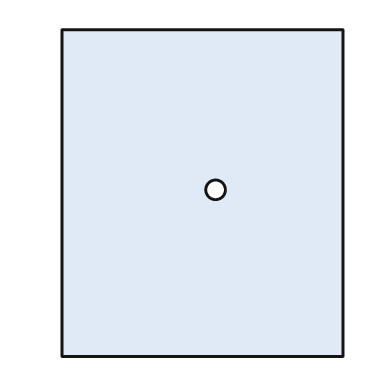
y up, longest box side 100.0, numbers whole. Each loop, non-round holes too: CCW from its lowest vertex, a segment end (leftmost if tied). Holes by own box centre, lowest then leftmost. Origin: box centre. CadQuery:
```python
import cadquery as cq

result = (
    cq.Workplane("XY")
    .moveTo(-43.0, -50.0)
    .lineTo(43.0, -50.0)
    .lineTo(43.0, 50.0)
    .lineTo(-43.0, 50.0)
    .close()
    .moveTo(4.0, 1.0)
    .circle(3.0)
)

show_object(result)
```